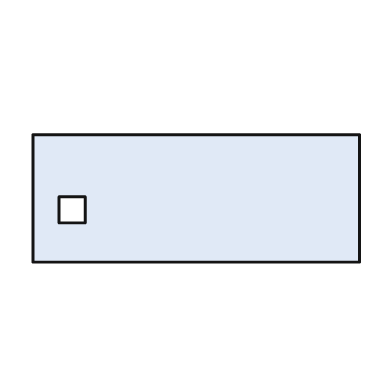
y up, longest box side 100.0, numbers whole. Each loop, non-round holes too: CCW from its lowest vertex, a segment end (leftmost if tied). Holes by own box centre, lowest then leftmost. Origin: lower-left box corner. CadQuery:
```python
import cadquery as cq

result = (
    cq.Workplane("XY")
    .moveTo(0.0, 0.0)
    .lineTo(100.0, 0.0)
    .lineTo(100.0, 39.0)
    .lineTo(0.0, 39.0)
    .close()
    .moveTo(8.0, 12.0)
    .lineTo(16.0, 12.0)
    .lineTo(16.0, 20.0)
    .lineTo(8.0, 20.0)
    .close()
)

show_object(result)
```